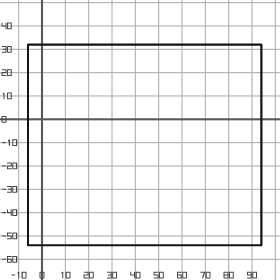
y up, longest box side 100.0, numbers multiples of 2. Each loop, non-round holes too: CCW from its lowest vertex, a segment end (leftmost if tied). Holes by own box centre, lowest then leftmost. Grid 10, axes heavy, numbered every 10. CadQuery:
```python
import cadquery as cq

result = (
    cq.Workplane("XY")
    .moveTo(-6.0, -54.0)
    .lineTo(94.0, -54.0)
    .lineTo(94.0, 32.0)
    .lineTo(-6.0, 32.0)
    .close()
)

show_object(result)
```